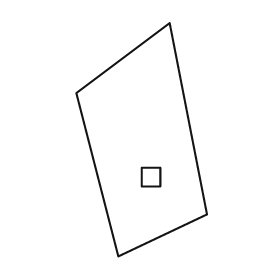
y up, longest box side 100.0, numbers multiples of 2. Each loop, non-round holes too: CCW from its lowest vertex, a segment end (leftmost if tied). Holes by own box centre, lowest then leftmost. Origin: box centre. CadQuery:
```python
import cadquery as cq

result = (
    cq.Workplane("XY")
    .moveTo(-10.0, -50.0)
    .lineTo(28.0, -32.0)
    .lineTo(12.0, 50.0)
    .lineTo(-28.0, 20.0)
    .close()
    .moveTo(0.0, -20.0)
    .lineTo(8.0, -20.0)
    .lineTo(8.0, -12.0)
    .lineTo(0.0, -12.0)
    .close()
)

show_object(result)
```